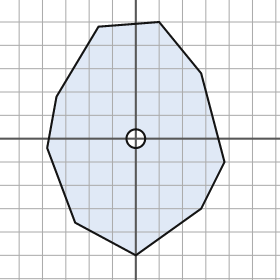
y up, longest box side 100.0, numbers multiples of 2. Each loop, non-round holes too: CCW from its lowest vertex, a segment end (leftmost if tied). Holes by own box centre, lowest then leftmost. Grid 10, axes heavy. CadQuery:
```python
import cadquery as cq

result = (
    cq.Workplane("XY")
    .moveTo(0.0, -50.0)
    .lineTo(28.0, -30.0)
    .lineTo(38.0, -10.0)
    .lineTo(28.0, 28.0)
    .lineTo(10.0, 50.0)
    .lineTo(-16.0, 48.0)
    .lineTo(-34.0, 18.0)
    .lineTo(-38.0, -4.0)
    .lineTo(-26.0, -36.0)
    .close()
    .moveTo(0.0, 0.0)
    .circle(4.0)
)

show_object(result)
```